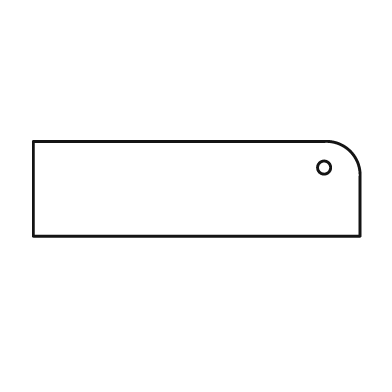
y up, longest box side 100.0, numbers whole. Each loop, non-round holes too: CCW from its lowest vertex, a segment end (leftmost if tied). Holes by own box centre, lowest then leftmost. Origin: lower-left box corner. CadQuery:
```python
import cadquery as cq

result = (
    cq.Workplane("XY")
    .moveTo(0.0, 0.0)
    .lineTo(100.0, 0.0)
    .lineTo(100.0, 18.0)
    .threePointArc((97.0, 26.0), (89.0, 29.0))
    .lineTo(0.0, 29.0)
    .close()
    .moveTo(89.0, 21.0)
    .circle(2.0)
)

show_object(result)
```